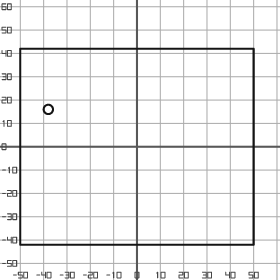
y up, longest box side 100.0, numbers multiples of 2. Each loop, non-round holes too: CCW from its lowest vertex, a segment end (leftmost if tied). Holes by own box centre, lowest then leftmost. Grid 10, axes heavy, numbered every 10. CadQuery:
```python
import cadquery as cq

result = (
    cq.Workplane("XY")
    .moveTo(-50.0, -42.0)
    .lineTo(50.0, -42.0)
    .lineTo(50.0, 42.0)
    .lineTo(-50.0, 42.0)
    .close()
    .moveTo(-38.0, 16.0)
    .circle(2.0)
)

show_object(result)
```